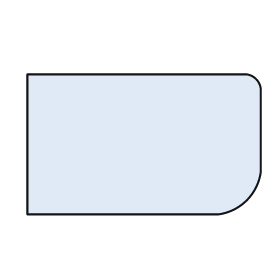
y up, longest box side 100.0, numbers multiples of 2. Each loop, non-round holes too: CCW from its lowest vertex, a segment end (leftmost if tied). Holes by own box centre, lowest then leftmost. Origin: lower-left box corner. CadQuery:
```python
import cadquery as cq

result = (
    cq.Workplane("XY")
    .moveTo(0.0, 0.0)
    .lineTo(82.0, 0.0)
    .threePointArc((94.0, 6.0), (100.0, 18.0))
    .lineTo(100.0, 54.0)
    .threePointArc((98.0, 58.0), (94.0, 60.0))
    .lineTo(0.0, 60.0)
    .close()
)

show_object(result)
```